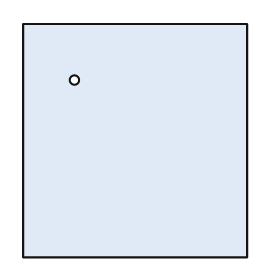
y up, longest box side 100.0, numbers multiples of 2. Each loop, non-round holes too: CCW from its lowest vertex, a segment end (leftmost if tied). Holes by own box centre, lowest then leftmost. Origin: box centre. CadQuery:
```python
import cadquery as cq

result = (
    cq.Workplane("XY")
    .moveTo(-48.0, -50.0)
    .lineTo(48.0, -50.0)
    .lineTo(48.0, 50.0)
    .lineTo(-48.0, 50.0)
    .close()
    .moveTo(-26.0, 26.0)
    .circle(2.0)
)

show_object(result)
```